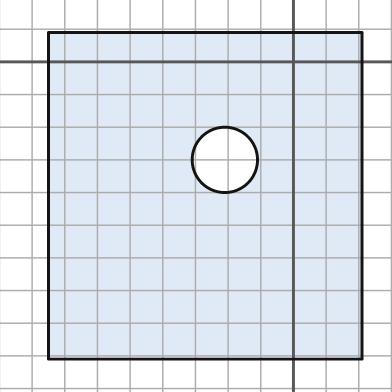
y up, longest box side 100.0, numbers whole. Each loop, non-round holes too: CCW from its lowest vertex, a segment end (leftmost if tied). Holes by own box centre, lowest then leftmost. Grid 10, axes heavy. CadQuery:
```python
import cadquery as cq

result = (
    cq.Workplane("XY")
    .moveTo(-75.0, -91.0)
    .lineTo(21.0, -91.0)
    .lineTo(21.0, 9.0)
    .lineTo(-75.0, 9.0)
    .close()
    .moveTo(-21.0, -30.0)
    .circle(10.0)
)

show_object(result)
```